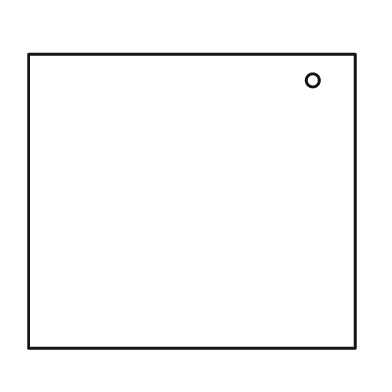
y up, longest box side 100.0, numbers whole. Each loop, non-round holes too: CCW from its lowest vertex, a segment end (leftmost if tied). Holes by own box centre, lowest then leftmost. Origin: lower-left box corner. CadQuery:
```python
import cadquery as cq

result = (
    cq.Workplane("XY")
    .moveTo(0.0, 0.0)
    .lineTo(100.0, 0.0)
    .lineTo(100.0, 90.0)
    .lineTo(0.0, 90.0)
    .close()
    .moveTo(87.0, 82.0)
    .circle(2.0)
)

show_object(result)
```